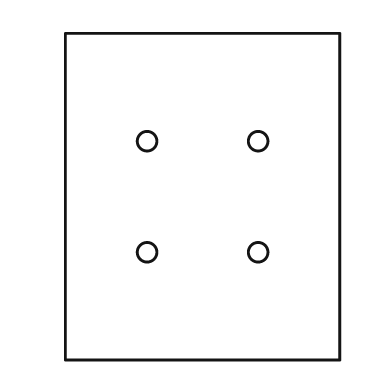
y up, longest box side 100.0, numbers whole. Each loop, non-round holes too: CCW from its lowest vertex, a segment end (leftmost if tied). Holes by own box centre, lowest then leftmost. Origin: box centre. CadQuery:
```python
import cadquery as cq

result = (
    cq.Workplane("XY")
    .moveTo(-42.0, -50.0)
    .lineTo(42.0, -50.0)
    .lineTo(42.0, 50.0)
    .lineTo(-42.0, 50.0)
    .close()
    .moveTo(-17.0, -17.0)
    .circle(3.0)
    .moveTo(17.0, -17.0)
    .circle(3.0)
    .moveTo(-17.0, 17.0)
    .circle(3.0)
    .moveTo(17.0, 17.0)
    .circle(3.0)
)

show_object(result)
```